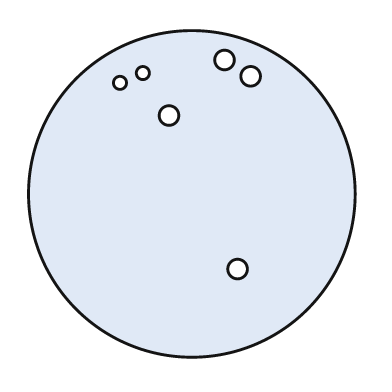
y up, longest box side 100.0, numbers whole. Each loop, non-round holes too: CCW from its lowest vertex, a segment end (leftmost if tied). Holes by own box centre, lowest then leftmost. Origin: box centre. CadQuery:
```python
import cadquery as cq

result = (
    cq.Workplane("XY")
    .moveTo(0.0, 0.0)
    .circle(50.0)
    .moveTo(14.0, -23.0)
    .circle(3.0)
    .moveTo(-7.0, 24.0)
    .circle(3.0)
    .moveTo(-22.0, 34.0)
    .circle(2.0)
    .moveTo(18.0, 36.0)
    .circle(3.0)
    .moveTo(-15.0, 37.0)
    .circle(2.0)
    .moveTo(10.0, 41.0)
    .circle(3.0)
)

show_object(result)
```